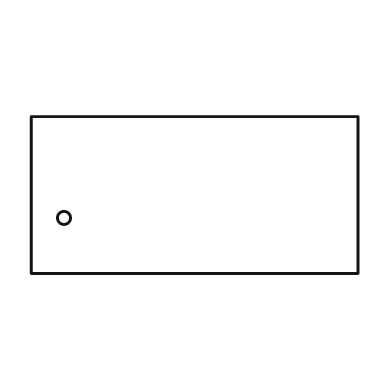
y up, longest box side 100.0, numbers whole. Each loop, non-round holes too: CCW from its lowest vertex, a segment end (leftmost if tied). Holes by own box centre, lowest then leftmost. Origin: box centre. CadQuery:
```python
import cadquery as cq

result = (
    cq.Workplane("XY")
    .moveTo(-50.0, -24.0)
    .lineTo(50.0, -24.0)
    .lineTo(50.0, 24.0)
    .lineTo(-50.0, 24.0)
    .close()
    .moveTo(-40.0, -7.0)
    .circle(2.0)
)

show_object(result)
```